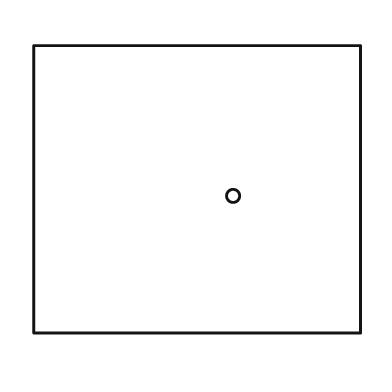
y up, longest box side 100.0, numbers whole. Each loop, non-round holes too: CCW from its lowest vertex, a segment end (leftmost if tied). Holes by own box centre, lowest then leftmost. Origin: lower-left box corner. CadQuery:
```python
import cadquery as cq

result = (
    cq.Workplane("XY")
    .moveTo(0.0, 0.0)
    .lineTo(100.0, 0.0)
    .lineTo(100.0, 88.0)
    .lineTo(0.0, 88.0)
    .close()
    .moveTo(61.0, 42.0)
    .circle(2.0)
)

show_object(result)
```